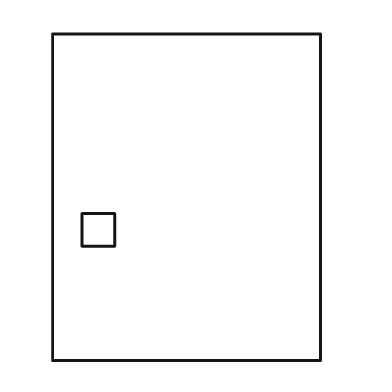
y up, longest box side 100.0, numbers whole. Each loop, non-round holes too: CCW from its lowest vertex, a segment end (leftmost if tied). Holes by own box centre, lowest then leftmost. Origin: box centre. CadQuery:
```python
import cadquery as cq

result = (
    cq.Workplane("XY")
    .moveTo(-41.0, -50.0)
    .lineTo(41.0, -50.0)
    .lineTo(41.0, 50.0)
    .lineTo(-41.0, 50.0)
    .close()
    .moveTo(-32.0, -15.0)
    .lineTo(-22.0, -15.0)
    .lineTo(-22.0, -5.0)
    .lineTo(-32.0, -5.0)
    .close()
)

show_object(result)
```